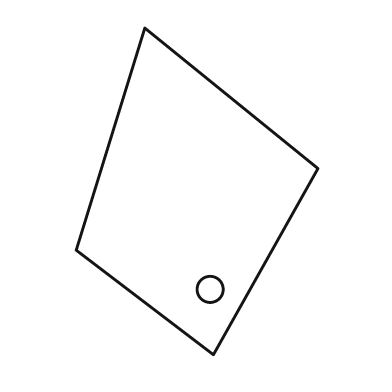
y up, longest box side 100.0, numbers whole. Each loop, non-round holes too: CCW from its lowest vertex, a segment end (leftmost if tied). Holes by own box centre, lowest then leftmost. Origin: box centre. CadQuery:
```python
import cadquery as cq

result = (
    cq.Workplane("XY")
    .moveTo(5.0, -50.0)
    .lineTo(37.0, 7.0)
    .lineTo(-16.0, 50.0)
    .lineTo(-37.0, -18.0)
    .close()
    .moveTo(4.0, -30.0)
    .circle(4.0)
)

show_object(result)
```